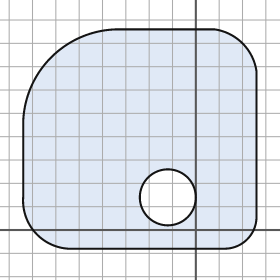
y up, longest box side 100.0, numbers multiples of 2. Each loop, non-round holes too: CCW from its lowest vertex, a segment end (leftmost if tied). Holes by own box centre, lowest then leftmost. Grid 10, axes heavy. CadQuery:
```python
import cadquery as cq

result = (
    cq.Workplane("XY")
    .moveTo(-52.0, -8.0)
    .lineTo(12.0, -8.0)
    .threePointArc((22.0, -4.0), (26.0, 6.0))
    .lineTo(26.0, 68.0)
    .threePointArc((20.0, 80.0), (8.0, 86.0))
    .lineTo(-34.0, 86.0)
    .threePointArc((-62.0, 74.0), (-74.0, 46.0))
    .lineTo(-74.0, 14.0)
    .threePointArc((-68.0, -2.0), (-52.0, -8.0))
    .close()
    .moveTo(-12.0, 14.0)
    .circle(12.0)
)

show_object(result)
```